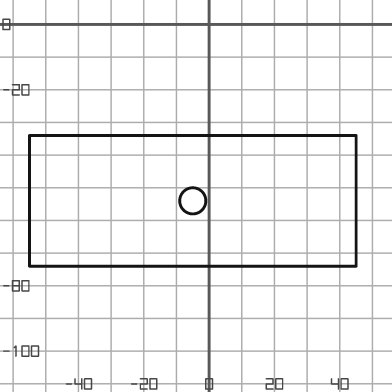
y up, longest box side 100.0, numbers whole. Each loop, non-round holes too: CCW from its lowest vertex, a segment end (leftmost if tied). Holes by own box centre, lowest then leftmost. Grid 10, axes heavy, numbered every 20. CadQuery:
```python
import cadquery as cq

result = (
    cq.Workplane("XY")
    .moveTo(-55.0, -74.0)
    .lineTo(45.0, -74.0)
    .lineTo(45.0, -34.0)
    .lineTo(-55.0, -34.0)
    .close()
    .moveTo(-5.0, -54.0)
    .circle(4.0)
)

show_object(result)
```